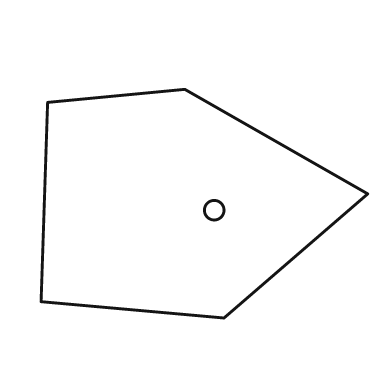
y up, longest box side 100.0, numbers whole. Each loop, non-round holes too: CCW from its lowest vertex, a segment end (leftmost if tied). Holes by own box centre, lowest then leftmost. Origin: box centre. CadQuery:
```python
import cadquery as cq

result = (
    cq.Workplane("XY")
    .moveTo(6.0, -35.0)
    .lineTo(50.0, 3.0)
    .lineTo(-6.0, 35.0)
    .lineTo(-48.0, 31.0)
    .lineTo(-50.0, -30.0)
    .close()
    .moveTo(3.0, -2.0)
    .circle(3.0)
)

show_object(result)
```